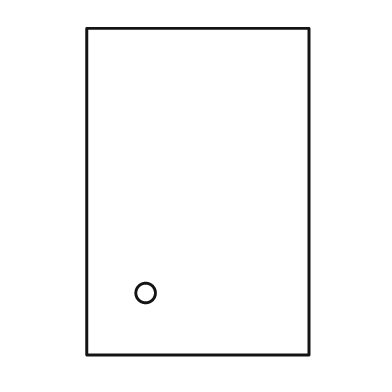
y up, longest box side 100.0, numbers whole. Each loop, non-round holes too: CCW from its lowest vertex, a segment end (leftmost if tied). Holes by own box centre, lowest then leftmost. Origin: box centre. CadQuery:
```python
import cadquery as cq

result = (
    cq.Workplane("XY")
    .moveTo(-34.0, -50.0)
    .lineTo(34.0, -50.0)
    .lineTo(34.0, 50.0)
    .lineTo(-34.0, 50.0)
    .close()
    .moveTo(-16.0, -31.0)
    .circle(3.0)
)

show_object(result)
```